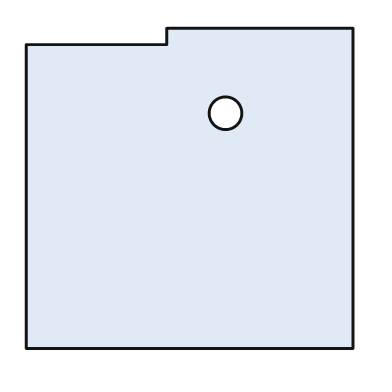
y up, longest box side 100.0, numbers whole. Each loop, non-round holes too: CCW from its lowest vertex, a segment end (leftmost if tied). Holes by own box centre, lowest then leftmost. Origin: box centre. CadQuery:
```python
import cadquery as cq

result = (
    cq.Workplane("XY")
    .moveTo(-50.0, -49.0)
    .lineTo(50.0, -49.0)
    .lineTo(50.0, 49.0)
    .lineTo(-7.0, 49.0)
    .lineTo(-7.0, 44.0)
    .lineTo(-50.0, 44.0)
    .close()
    .moveTo(11.0, 23.0)
    .circle(5.0)
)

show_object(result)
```